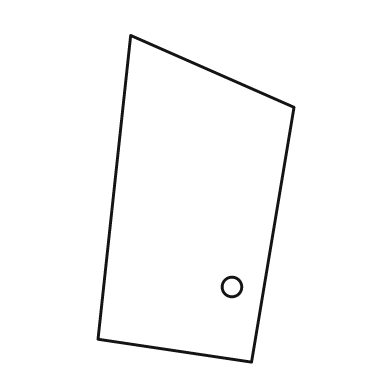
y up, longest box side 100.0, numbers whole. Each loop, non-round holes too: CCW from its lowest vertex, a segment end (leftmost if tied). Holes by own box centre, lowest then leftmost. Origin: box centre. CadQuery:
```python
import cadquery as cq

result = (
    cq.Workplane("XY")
    .moveTo(17.0, -50.0)
    .lineTo(30.0, 28.0)
    .lineTo(-20.0, 50.0)
    .lineTo(-30.0, -43.0)
    .close()
    .moveTo(11.0, -27.0)
    .circle(3.0)
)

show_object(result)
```